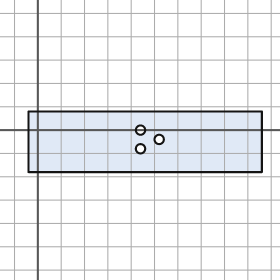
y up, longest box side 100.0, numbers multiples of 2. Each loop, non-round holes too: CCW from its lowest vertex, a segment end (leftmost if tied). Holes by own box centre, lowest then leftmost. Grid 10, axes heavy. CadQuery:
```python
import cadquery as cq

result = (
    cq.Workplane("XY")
    .moveTo(-4.0, -18.0)
    .lineTo(96.0, -18.0)
    .lineTo(96.0, 8.0)
    .lineTo(-4.0, 8.0)
    .close()
    .moveTo(44.0, -8.0)
    .circle(2.0)
    .moveTo(52.0, -4.0)
    .circle(2.0)
    .moveTo(44.0, 0.0)
    .circle(2.0)
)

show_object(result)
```